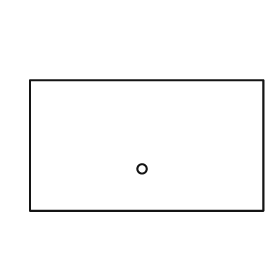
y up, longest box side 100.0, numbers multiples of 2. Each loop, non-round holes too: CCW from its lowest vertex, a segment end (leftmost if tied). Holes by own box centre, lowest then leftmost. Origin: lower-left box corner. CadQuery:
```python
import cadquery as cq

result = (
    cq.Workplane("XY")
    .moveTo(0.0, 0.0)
    .lineTo(100.0, 0.0)
    .lineTo(100.0, 56.0)
    .lineTo(0.0, 56.0)
    .close()
    .moveTo(48.0, 18.0)
    .circle(2.0)
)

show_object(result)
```